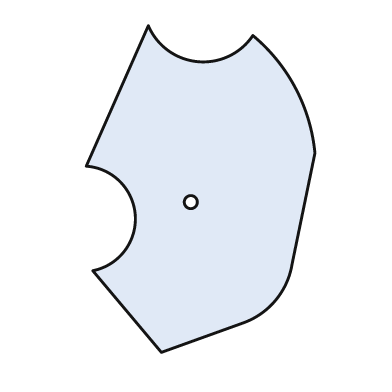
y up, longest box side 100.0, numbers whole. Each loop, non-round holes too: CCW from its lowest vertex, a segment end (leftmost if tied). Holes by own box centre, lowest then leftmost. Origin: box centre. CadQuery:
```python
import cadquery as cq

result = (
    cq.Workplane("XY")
    .moveTo(-12.0, -50.0)
    .lineTo(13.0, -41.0)
    .threePointArc((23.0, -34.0), (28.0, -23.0))
    .lineTo(35.0, 11.0)
    .threePointArc((29.0, 31.0), (16.0, 47.0))
    .threePointArc((-1.0, 39.0), (-16.0, 50.0))
    .lineTo(-35.0, 7.0)
    .threePointArc((-20.0, -8.0), (-33.0, -25.0))
    .close()
    .moveTo(-3.0, -4.0)
    .circle(2.0)
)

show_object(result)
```